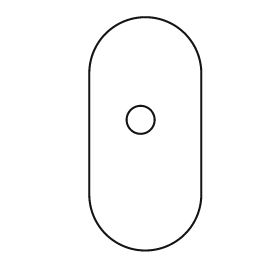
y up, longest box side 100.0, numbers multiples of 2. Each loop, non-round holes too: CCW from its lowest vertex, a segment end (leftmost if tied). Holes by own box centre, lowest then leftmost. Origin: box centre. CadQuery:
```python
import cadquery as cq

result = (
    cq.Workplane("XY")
    .moveTo(-24.0, -26.0)
    .threePointArc((0.0, -50.0), (24.0, -26.0))
    .lineTo(24.0, 26.0)
    .threePointArc((0.0, 50.0), (-24.0, 26.0))
    .close()
    .moveTo(-2.0, 6.0)
    .circle(6.0)
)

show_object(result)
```